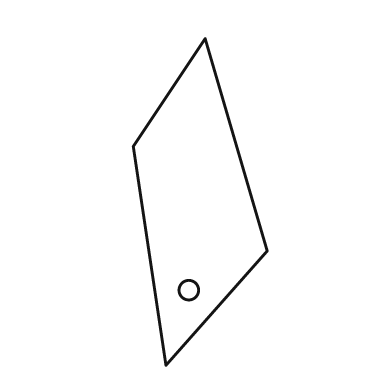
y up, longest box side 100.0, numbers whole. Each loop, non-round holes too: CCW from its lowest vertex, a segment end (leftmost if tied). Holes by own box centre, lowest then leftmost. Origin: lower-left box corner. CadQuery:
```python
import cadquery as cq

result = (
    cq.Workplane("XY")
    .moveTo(10.0, 0.0)
    .lineTo(41.0, 35.0)
    .lineTo(22.0, 100.0)
    .lineTo(0.0, 67.0)
    .close()
    .moveTo(17.0, 23.0)
    .circle(3.0)
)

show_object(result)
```